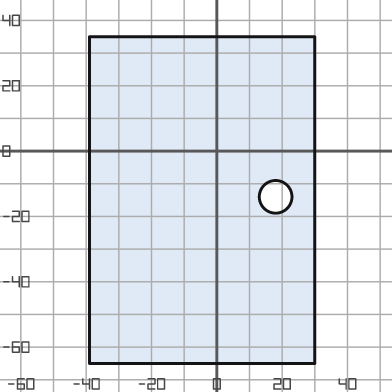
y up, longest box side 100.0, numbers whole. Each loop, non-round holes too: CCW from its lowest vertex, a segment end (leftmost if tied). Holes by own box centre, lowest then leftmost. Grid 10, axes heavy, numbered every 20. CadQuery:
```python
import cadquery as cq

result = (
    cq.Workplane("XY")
    .moveTo(-39.0, -65.0)
    .lineTo(30.0, -65.0)
    .lineTo(30.0, 35.0)
    .lineTo(-39.0, 35.0)
    .close()
    .moveTo(18.0, -14.0)
    .circle(5.0)
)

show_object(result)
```